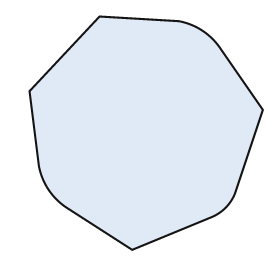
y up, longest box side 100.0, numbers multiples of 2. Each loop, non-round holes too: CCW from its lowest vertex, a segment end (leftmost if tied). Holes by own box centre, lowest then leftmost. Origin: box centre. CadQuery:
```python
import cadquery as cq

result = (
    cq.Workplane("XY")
    .moveTo(-6.0, -50.0)
    .lineTo(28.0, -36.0)
    .threePointArc((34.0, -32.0), (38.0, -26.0))
    .lineTo(50.0, 10.0)
    .lineTo(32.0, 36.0)
    .threePointArc((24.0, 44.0), (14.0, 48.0))
    .lineTo(-20.0, 50.0)
    .lineTo(-50.0, 18.0)
    .lineTo(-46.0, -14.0)
    .threePointArc((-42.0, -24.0), (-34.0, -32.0))
    .close()
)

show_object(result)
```